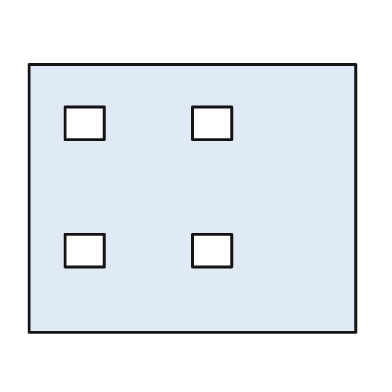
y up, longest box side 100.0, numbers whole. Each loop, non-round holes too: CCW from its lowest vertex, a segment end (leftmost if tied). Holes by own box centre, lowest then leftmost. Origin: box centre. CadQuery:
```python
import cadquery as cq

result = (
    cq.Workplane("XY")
    .moveTo(-50.0, -41.0)
    .lineTo(50.0, -41.0)
    .lineTo(50.0, 41.0)
    .lineTo(-50.0, 41.0)
    .close()
    .moveTo(-39.0, -21.0)
    .lineTo(-27.0, -21.0)
    .lineTo(-27.0, -11.0)
    .lineTo(-39.0, -11.0)
    .close()
    .moveTo(0.0, -21.0)
    .lineTo(12.0, -21.0)
    .lineTo(12.0, -11.0)
    .lineTo(0.0, -11.0)
    .close()
    .moveTo(-39.0, 18.0)
    .lineTo(-27.0, 18.0)
    .lineTo(-27.0, 28.0)
    .lineTo(-39.0, 28.0)
    .close()
    .moveTo(0.0, 18.0)
    .lineTo(12.0, 18.0)
    .lineTo(12.0, 28.0)
    .lineTo(0.0, 28.0)
    .close()
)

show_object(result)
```